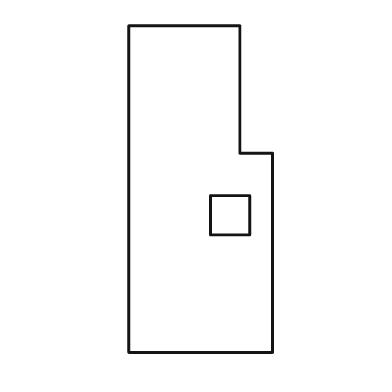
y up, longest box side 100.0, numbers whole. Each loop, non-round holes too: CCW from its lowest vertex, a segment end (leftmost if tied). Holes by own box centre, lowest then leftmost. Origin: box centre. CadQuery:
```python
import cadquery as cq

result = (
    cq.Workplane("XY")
    .moveTo(-22.0, -50.0)
    .lineTo(22.0, -50.0)
    .lineTo(22.0, 11.0)
    .lineTo(12.0, 11.0)
    .lineTo(12.0, 50.0)
    .lineTo(-22.0, 50.0)
    .close()
    .moveTo(3.0, -14.0)
    .lineTo(15.0, -14.0)
    .lineTo(15.0, -2.0)
    .lineTo(3.0, -2.0)
    .close()
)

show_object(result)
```